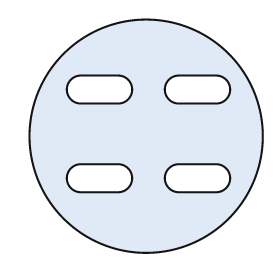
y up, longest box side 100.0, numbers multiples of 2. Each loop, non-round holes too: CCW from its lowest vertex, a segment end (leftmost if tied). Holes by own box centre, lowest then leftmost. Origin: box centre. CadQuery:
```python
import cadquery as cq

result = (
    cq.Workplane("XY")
    .moveTo(0.0, 0.0)
    .circle(50.0)
    .moveTo(-28.0, -24.0)
    .lineTo(-12.0, -24.0)
    .threePointArc((-6.0, -18.0), (-12.0, -12.0))
    .lineTo(-28.0, -12.0)
    .threePointArc((-34.0, -18.0), (-28.0, -24.0))
    .close()
    .moveTo(14.0, -24.0)
    .lineTo(30.0, -24.0)
    .threePointArc((36.0, -18.0), (30.0, -12.0))
    .lineTo(14.0, -12.0)
    .threePointArc((8.0, -18.0), (14.0, -24.0))
    .close()
    .moveTo(-28.0, 14.0)
    .lineTo(-12.0, 14.0)
    .threePointArc((-6.0, 20.0), (-12.0, 26.0))
    .lineTo(-28.0, 26.0)
    .threePointArc((-34.0, 20.0), (-28.0, 14.0))
    .close()
    .moveTo(14.0, 14.0)
    .lineTo(30.0, 14.0)
    .threePointArc((36.0, 20.0), (30.0, 26.0))
    .lineTo(14.0, 26.0)
    .threePointArc((8.0, 20.0), (14.0, 14.0))
    .close()
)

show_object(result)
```